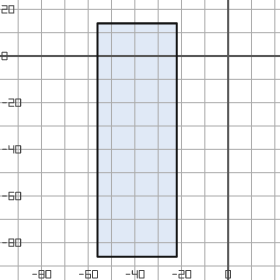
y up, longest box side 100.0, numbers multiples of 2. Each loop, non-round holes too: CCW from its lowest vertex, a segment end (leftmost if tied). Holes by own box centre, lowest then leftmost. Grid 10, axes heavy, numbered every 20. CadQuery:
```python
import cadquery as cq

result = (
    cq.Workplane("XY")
    .moveTo(-56.0, -86.0)
    .lineTo(-22.0, -86.0)
    .lineTo(-22.0, 14.0)
    .lineTo(-56.0, 14.0)
    .close()
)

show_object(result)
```